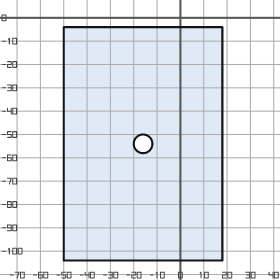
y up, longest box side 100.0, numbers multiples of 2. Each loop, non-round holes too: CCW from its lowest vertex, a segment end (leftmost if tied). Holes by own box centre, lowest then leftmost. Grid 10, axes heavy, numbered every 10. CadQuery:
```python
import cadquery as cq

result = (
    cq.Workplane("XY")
    .moveTo(-50.0, -104.0)
    .lineTo(18.0, -104.0)
    .lineTo(18.0, -4.0)
    .lineTo(-50.0, -4.0)
    .close()
    .moveTo(-16.0, -54.0)
    .circle(4.0)
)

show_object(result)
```